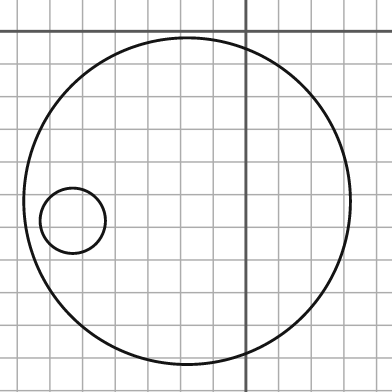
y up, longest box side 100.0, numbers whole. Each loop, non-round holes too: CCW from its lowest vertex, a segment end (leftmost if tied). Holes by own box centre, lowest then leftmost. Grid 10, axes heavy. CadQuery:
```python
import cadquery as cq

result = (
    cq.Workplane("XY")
    .moveTo(-18.0, -52.0)
    .circle(50.0)
    .moveTo(-53.0, -58.0)
    .circle(10.0)
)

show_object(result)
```